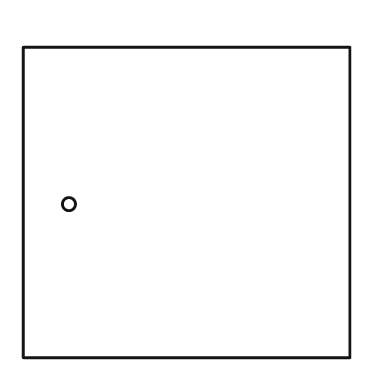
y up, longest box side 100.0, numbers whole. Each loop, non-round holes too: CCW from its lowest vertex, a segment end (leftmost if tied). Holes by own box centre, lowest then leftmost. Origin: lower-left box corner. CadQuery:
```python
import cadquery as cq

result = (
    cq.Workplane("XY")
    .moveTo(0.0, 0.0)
    .lineTo(100.0, 0.0)
    .lineTo(100.0, 95.0)
    .lineTo(0.0, 95.0)
    .close()
    .moveTo(14.0, 47.0)
    .circle(2.0)
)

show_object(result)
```